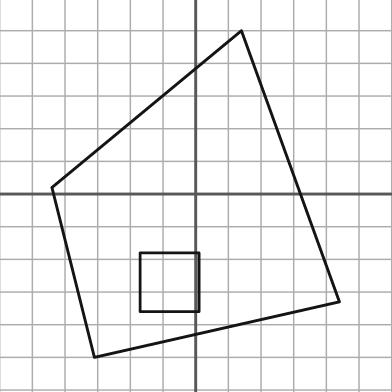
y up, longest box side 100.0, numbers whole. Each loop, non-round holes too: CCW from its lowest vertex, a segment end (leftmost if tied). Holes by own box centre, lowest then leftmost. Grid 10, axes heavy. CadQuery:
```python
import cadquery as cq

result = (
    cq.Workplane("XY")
    .moveTo(-31.0, -50.0)
    .lineTo(44.0, -33.0)
    .lineTo(14.0, 50.0)
    .lineTo(-44.0, 2.0)
    .close()
    .moveTo(-17.0, -36.0)
    .lineTo(1.0, -36.0)
    .lineTo(1.0, -18.0)
    .lineTo(-17.0, -18.0)
    .close()
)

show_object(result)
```